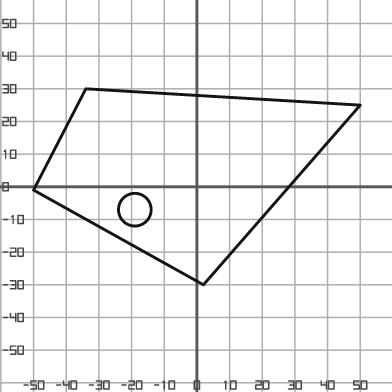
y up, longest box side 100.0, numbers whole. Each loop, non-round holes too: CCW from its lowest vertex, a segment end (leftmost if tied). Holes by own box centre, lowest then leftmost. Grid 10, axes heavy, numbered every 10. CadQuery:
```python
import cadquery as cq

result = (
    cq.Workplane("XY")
    .moveTo(2.0, -30.0)
    .lineTo(50.0, 25.0)
    .lineTo(-34.0, 30.0)
    .lineTo(-50.0, -1.0)
    .close()
    .moveTo(-19.0, -7.0)
    .circle(5.0)
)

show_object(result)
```